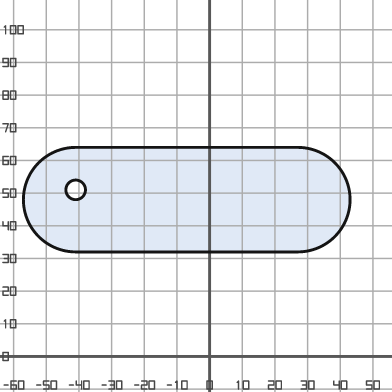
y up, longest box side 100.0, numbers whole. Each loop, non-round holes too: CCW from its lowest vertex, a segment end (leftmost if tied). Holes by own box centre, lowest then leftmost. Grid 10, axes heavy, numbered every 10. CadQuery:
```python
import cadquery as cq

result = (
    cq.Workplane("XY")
    .moveTo(-41.0, 32.0)
    .lineTo(27.0, 32.0)
    .threePointArc((43.0, 48.0), (27.0, 64.0))
    .lineTo(-41.0, 64.0)
    .threePointArc((-57.0, 48.0), (-41.0, 32.0))
    .close()
    .moveTo(-41.0, 51.0)
    .circle(3.0)
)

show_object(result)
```